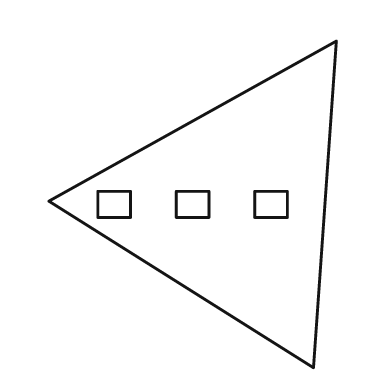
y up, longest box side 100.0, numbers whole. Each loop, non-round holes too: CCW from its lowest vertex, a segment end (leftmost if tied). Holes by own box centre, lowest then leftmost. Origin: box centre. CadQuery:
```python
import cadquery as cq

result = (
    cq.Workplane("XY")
    .moveTo(37.0, -50.0)
    .lineTo(44.0, 50.0)
    .lineTo(-44.0, 1.0)
    .close()
    .moveTo(-29.0, -4.0)
    .lineTo(-19.0, -4.0)
    .lineTo(-19.0, 4.0)
    .lineTo(-29.0, 4.0)
    .close()
    .moveTo(-5.0, -4.0)
    .lineTo(5.0, -4.0)
    .lineTo(5.0, 4.0)
    .lineTo(-5.0, 4.0)
    .close()
    .moveTo(19.0, -4.0)
    .lineTo(29.0, -4.0)
    .lineTo(29.0, 4.0)
    .lineTo(19.0, 4.0)
    .close()
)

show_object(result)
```